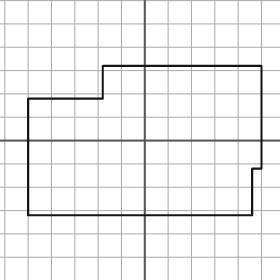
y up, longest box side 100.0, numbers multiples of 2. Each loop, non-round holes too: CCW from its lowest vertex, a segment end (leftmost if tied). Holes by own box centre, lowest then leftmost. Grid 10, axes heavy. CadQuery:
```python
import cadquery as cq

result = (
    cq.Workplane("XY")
    .moveTo(-50.0, -32.0)
    .lineTo(46.0, -32.0)
    .lineTo(46.0, -12.0)
    .lineTo(50.0, -12.0)
    .lineTo(50.0, 32.0)
    .lineTo(-18.0, 32.0)
    .lineTo(-18.0, 18.0)
    .lineTo(-50.0, 18.0)
    .close()
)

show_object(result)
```